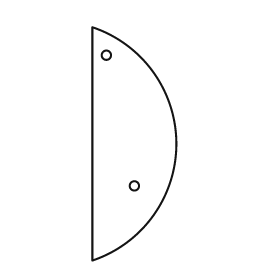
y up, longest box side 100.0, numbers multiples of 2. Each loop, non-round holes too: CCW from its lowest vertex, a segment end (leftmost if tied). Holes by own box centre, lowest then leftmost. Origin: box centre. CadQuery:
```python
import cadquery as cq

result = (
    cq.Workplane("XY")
    .moveTo(-18.0, -50.0)
    .threePointArc((18.0, 0.0), (-18.0, 50.0))
    .close()
    .moveTo(0.0, -18.0)
    .circle(2.0)
    .moveTo(-12.0, 38.0)
    .circle(2.0)
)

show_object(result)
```